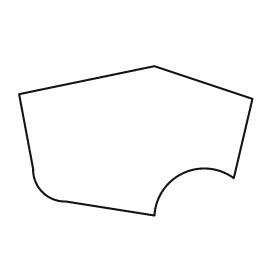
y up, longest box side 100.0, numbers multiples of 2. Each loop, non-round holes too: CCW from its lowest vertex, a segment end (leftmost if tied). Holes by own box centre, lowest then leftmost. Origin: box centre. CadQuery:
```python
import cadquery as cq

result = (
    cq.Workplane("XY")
    .moveTo(8.0, -32.0)
    .threePointArc((20.0, -14.0), (42.0, -16.0))
    .lineTo(50.0, 18.0)
    .lineTo(8.0, 32.0)
    .lineTo(-50.0, 20.0)
    .lineTo(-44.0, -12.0)
    .threePointArc((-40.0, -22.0), (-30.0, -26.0))
    .close()
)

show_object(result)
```